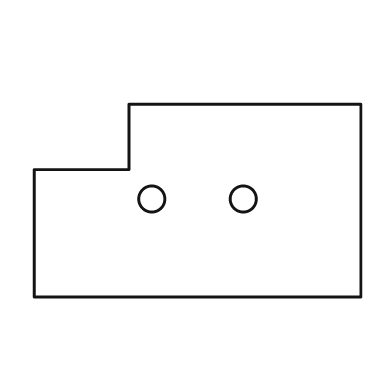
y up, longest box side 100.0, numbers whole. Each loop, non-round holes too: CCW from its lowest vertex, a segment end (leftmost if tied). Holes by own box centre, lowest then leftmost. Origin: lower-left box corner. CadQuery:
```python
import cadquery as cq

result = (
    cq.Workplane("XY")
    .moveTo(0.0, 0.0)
    .lineTo(100.0, 0.0)
    .lineTo(100.0, 59.0)
    .lineTo(29.0, 59.0)
    .lineTo(29.0, 39.0)
    .lineTo(0.0, 39.0)
    .close()
    .moveTo(36.0, 30.0)
    .circle(4.0)
    .moveTo(64.0, 30.0)
    .circle(4.0)
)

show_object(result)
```